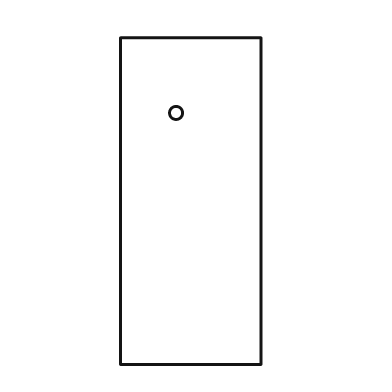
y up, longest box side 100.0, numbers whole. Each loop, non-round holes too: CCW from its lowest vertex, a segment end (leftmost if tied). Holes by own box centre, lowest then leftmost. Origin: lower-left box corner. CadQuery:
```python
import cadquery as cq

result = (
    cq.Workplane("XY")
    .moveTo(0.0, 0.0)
    .lineTo(43.0, 0.0)
    .lineTo(43.0, 100.0)
    .lineTo(0.0, 100.0)
    .close()
    .moveTo(17.0, 77.0)
    .circle(2.0)
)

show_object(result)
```